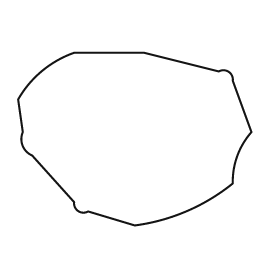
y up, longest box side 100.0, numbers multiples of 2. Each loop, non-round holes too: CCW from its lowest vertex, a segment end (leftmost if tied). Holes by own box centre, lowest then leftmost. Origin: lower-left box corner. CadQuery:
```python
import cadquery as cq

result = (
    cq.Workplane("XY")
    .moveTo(50.0, 0.0)
    .threePointArc((72.0, 6.0), (92.0, 18.0))
    .threePointArc((94.0, 30.0), (100.0, 40.0))
    .lineTo(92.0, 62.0)
    .threePointArc((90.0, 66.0), (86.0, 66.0))
    .lineTo(54.0, 74.0)
    .lineTo(24.0, 74.0)
    .threePointArc((10.0, 66.0), (0.0, 54.0))
    .lineTo(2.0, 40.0)
    .threePointArc((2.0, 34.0), (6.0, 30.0))
    .lineTo(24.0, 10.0)
    .threePointArc((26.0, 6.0), (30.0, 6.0))
    .close()
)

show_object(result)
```